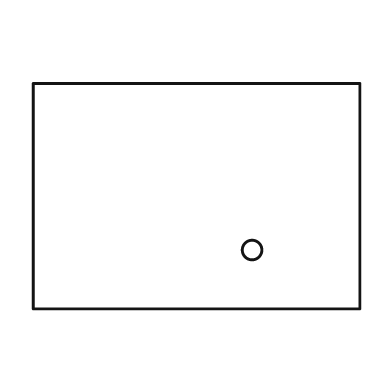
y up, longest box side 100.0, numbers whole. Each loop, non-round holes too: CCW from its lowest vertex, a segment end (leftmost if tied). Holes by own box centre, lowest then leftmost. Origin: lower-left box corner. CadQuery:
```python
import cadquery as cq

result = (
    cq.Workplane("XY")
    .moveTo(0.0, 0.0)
    .lineTo(100.0, 0.0)
    .lineTo(100.0, 69.0)
    .lineTo(0.0, 69.0)
    .close()
    .moveTo(67.0, 18.0)
    .circle(3.0)
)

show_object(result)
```